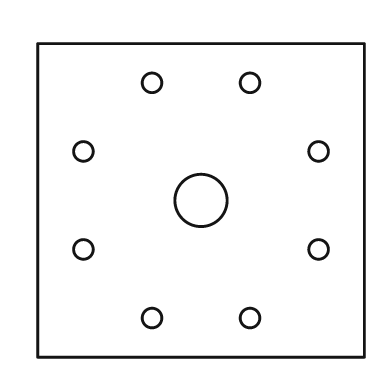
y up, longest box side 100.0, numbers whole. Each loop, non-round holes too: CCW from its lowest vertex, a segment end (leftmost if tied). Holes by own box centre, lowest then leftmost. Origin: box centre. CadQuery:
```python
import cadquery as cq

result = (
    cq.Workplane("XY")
    .moveTo(-50.0, -48.0)
    .lineTo(50.0, -48.0)
    .lineTo(50.0, 48.0)
    .lineTo(-50.0, 48.0)
    .close()
    .moveTo(-15.0, -36.0)
    .circle(3.0)
    .moveTo(15.0, -36.0)
    .circle(3.0)
    .moveTo(-36.0, -15.0)
    .circle(3.0)
    .moveTo(36.0, -15.0)
    .circle(3.0)
    .moveTo(0.0, 0.0)
    .circle(8.0)
    .moveTo(-36.0, 15.0)
    .circle(3.0)
    .moveTo(36.0, 15.0)
    .circle(3.0)
    .moveTo(-15.0, 36.0)
    .circle(3.0)
    .moveTo(15.0, 36.0)
    .circle(3.0)
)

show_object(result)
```